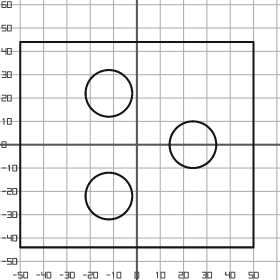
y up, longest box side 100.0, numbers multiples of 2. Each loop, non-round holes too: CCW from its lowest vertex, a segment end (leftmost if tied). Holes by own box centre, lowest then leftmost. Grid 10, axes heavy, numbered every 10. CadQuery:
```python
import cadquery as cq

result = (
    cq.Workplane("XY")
    .moveTo(-50.0, -44.0)
    .lineTo(50.0, -44.0)
    .lineTo(50.0, 44.0)
    .lineTo(-50.0, 44.0)
    .close()
    .moveTo(-12.0, -22.0)
    .circle(10.0)
    .moveTo(24.0, 0.0)
    .circle(10.0)
    .moveTo(-12.0, 22.0)
    .circle(10.0)
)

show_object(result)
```